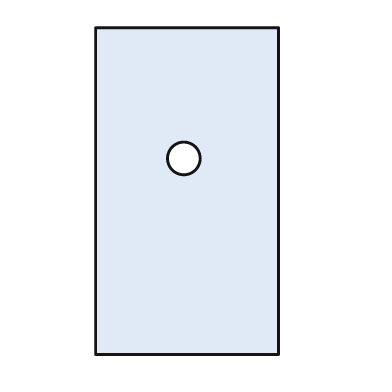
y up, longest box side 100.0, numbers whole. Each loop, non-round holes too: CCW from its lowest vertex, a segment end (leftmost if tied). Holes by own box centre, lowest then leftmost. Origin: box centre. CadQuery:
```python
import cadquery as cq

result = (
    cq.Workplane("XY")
    .moveTo(-28.0, -50.0)
    .lineTo(28.0, -50.0)
    .lineTo(28.0, 50.0)
    .lineTo(-28.0, 50.0)
    .close()
    .moveTo(-1.0, 10.0)
    .circle(5.0)
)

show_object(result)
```